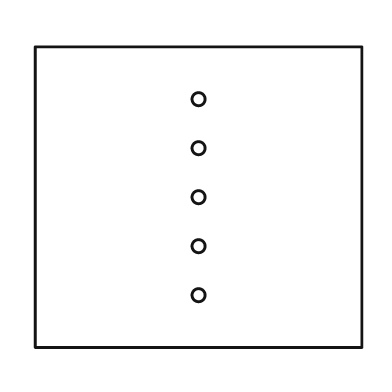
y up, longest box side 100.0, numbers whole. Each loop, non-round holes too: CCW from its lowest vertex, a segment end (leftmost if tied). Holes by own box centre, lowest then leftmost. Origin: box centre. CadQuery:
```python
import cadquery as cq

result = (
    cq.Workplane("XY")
    .moveTo(-50.0, -46.0)
    .lineTo(50.0, -46.0)
    .lineTo(50.0, 46.0)
    .lineTo(-50.0, 46.0)
    .close()
    .moveTo(0.0, -30.0)
    .circle(2.0)
    .moveTo(0.0, -15.0)
    .circle(2.0)
    .moveTo(0.0, 0.0)
    .circle(2.0)
    .moveTo(0.0, 15.0)
    .circle(2.0)
    .moveTo(0.0, 30.0)
    .circle(2.0)
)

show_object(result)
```